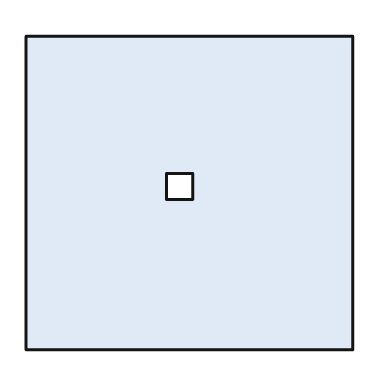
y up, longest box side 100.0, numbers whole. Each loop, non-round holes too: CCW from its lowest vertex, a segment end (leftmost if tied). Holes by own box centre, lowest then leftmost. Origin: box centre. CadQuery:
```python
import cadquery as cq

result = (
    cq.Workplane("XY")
    .moveTo(-50.0, -48.0)
    .lineTo(50.0, -48.0)
    .lineTo(50.0, 48.0)
    .lineTo(-50.0, 48.0)
    .close()
    .moveTo(-7.0, -2.0)
    .lineTo(1.0, -2.0)
    .lineTo(1.0, 6.0)
    .lineTo(-7.0, 6.0)
    .close()
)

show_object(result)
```